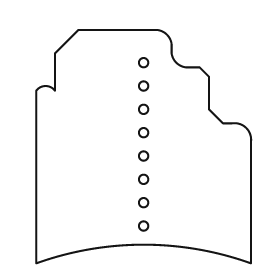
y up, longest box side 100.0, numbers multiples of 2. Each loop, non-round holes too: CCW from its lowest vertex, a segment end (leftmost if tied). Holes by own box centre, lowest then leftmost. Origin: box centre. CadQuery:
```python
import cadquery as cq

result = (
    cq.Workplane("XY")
    .moveTo(-46.0, -50.0)
    .threePointArc((0.0, -42.0), (46.0, -50.0))
    .lineTo(46.0, 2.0)
    .threePointArc((44.0, 8.0), (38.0, 10.0))
    .lineTo(34.0, 10.0)
    .lineTo(28.0, 16.0)
    .lineTo(28.0, 30.0)
    .lineTo(24.0, 34.0)
    .lineTo(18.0, 34.0)
    .threePointArc((14.0, 36.0), (12.0, 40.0))
    .lineTo(12.0, 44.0)
    .threePointArc((10.0, 48.0), (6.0, 50.0))
    .lineTo(-28.0, 50.0)
    .lineTo(-38.0, 40.0)
    .lineTo(-38.0, 24.0)
    .threePointArc((-42.0, 26.0), (-46.0, 24.0))
    .close()
    .moveTo(0.0, -34.0)
    .circle(2.0)
    .moveTo(0.0, -24.0)
    .circle(2.0)
    .moveTo(0.0, -14.0)
    .circle(2.0)
    .moveTo(0.0, -4.0)
    .circle(2.0)
    .moveTo(0.0, 6.0)
    .circle(2.0)
    .moveTo(0.0, 16.0)
    .circle(2.0)
    .moveTo(0.0, 26.0)
    .circle(2.0)
    .moveTo(0.0, 36.0)
    .circle(2.0)
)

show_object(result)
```